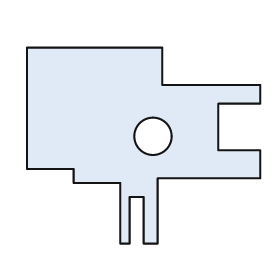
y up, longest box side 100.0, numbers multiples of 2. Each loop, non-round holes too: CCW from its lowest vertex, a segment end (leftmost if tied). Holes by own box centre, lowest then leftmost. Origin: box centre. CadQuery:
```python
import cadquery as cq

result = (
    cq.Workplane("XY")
    .moveTo(-10.0, -42.0)
    .lineTo(-6.0, -42.0)
    .lineTo(-6.0, -22.0)
    .lineTo(0.0, -22.0)
    .lineTo(0.0, -42.0)
    .lineTo(6.0, -42.0)
    .lineTo(6.0, -14.0)
    .lineTo(50.0, -14.0)
    .lineTo(50.0, -2.0)
    .lineTo(32.0, -2.0)
    .lineTo(32.0, 18.0)
    .lineTo(50.0, 18.0)
    .lineTo(50.0, 26.0)
    .lineTo(8.0, 26.0)
    .lineTo(8.0, 42.0)
    .lineTo(-50.0, 42.0)
    .lineTo(-50.0, -10.0)
    .lineTo(-30.0, -10.0)
    .lineTo(-30.0, -16.0)
    .lineTo(-10.0, -16.0)
    .close()
    .moveTo(4.0, 4.0)
    .circle(8.0)
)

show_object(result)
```